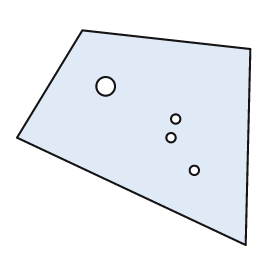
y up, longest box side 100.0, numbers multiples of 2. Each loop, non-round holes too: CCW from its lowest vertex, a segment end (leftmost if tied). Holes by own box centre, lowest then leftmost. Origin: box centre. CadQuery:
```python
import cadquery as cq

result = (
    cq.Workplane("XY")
    .moveTo(48.0, -46.0)
    .lineTo(50.0, 38.0)
    .lineTo(-22.0, 46.0)
    .lineTo(-50.0, 0.0)
    .close()
    .moveTo(26.0, -14.0)
    .circle(2.0)
    .moveTo(16.0, 0.0)
    .circle(2.0)
    .moveTo(18.0, 8.0)
    .circle(2.0)
    .moveTo(-12.0, 22.0)
    .circle(4.0)
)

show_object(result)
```